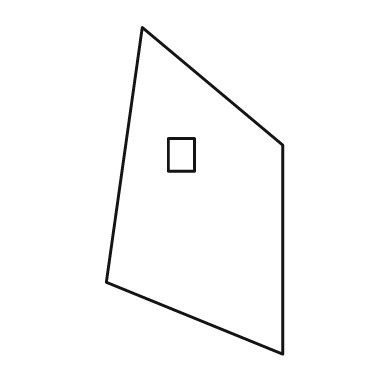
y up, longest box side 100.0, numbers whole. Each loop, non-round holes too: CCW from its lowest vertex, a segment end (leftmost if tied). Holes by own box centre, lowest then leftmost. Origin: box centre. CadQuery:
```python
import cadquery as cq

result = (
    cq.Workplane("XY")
    .moveTo(27.0, -50.0)
    .lineTo(27.0, 14.0)
    .lineTo(-16.0, 50.0)
    .lineTo(-27.0, -28.0)
    .close()
    .moveTo(-8.0, 6.0)
    .lineTo(0.0, 6.0)
    .lineTo(0.0, 16.0)
    .lineTo(-8.0, 16.0)
    .close()
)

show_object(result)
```